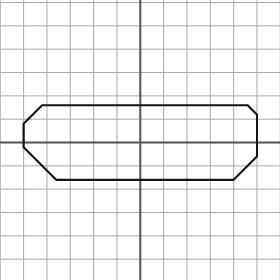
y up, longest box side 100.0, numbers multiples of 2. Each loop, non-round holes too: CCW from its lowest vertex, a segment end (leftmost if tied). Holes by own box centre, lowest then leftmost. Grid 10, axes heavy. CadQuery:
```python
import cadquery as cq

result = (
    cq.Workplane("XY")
    .moveTo(-36.0, -16.0)
    .lineTo(40.0, -16.0)
    .lineTo(50.0, -6.0)
    .lineTo(50.0, 12.0)
    .lineTo(46.0, 16.0)
    .lineTo(-42.0, 16.0)
    .lineTo(-50.0, 8.0)
    .lineTo(-50.0, -2.0)
    .close()
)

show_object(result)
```